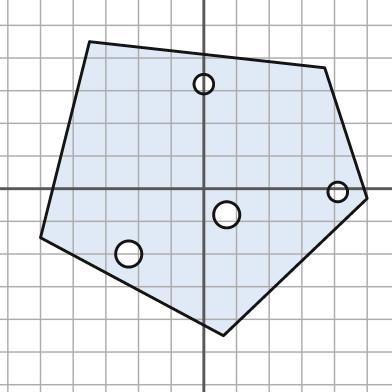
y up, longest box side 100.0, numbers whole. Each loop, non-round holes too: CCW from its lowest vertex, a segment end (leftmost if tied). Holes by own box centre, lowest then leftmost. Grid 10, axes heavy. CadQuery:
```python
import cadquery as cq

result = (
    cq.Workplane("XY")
    .moveTo(6.0, -45.0)
    .lineTo(50.0, -3.0)
    .lineTo(37.0, 37.0)
    .lineTo(-35.0, 45.0)
    .lineTo(-50.0, -15.0)
    .close()
    .moveTo(-23.0, -20.0)
    .circle(4.0)
    .moveTo(7.0, -8.0)
    .circle(4.0)
    .moveTo(41.0, -1.0)
    .circle(3.0)
    .moveTo(0.0, 32.0)
    .circle(3.0)
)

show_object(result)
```